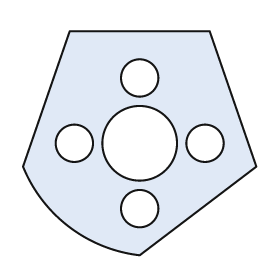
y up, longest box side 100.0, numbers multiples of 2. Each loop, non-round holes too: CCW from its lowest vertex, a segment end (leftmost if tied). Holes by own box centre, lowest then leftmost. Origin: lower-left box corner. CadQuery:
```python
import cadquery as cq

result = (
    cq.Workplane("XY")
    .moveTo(50.0, 0.0)
    .lineTo(100.0, 38.0)
    .lineTo(80.0, 96.0)
    .lineTo(20.0, 96.0)
    .lineTo(0.0, 38.0)
    .threePointArc((20.0, 12.0), (50.0, 0.0))
    .close()
    .moveTo(50.0, 20.0)
    .circle(8.0)
    .moveTo(22.0, 48.0)
    .circle(8.0)
    .moveTo(50.0, 48.0)
    .circle(16.0)
    .moveTo(78.0, 48.0)
    .circle(8.0)
    .moveTo(50.0, 76.0)
    .circle(8.0)
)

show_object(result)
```